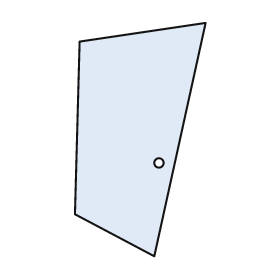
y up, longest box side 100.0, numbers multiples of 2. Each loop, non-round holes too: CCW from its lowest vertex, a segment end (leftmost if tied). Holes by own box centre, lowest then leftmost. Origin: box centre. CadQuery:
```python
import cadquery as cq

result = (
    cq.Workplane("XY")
    .moveTo(6.0, -50.0)
    .lineTo(28.0, 50.0)
    .lineTo(-26.0, 42.0)
    .lineTo(-28.0, -32.0)
    .close()
    .moveTo(8.0, -10.0)
    .circle(2.0)
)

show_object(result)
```